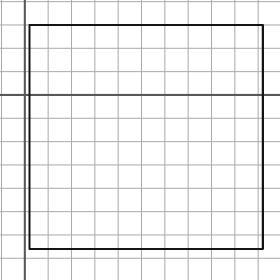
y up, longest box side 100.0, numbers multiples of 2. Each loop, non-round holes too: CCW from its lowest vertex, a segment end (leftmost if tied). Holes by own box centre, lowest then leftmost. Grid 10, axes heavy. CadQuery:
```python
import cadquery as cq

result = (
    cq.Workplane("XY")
    .moveTo(2.0, -66.0)
    .lineTo(102.0, -66.0)
    .lineTo(102.0, 30.0)
    .lineTo(2.0, 30.0)
    .close()
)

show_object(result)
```